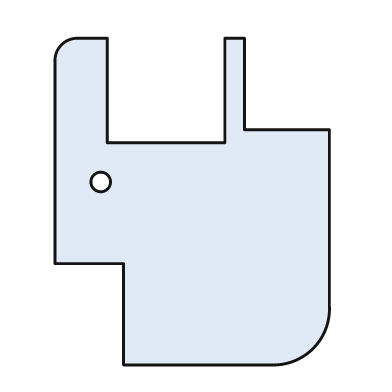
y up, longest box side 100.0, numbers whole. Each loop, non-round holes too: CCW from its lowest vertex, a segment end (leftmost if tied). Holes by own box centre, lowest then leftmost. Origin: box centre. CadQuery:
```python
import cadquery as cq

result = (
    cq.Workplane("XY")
    .moveTo(-21.0, -50.0)
    .lineTo(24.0, -50.0)
    .threePointArc((37.0, -45.0), (42.0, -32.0))
    .lineTo(42.0, 22.0)
    .lineTo(16.0, 22.0)
    .lineTo(16.0, 50.0)
    .lineTo(10.0, 50.0)
    .lineTo(10.0, 18.0)
    .lineTo(-26.0, 18.0)
    .lineTo(-26.0, 50.0)
    .lineTo(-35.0, 50.0)
    .threePointArc((-40.0, 48.0), (-42.0, 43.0))
    .lineTo(-42.0, -19.0)
    .lineTo(-21.0, -19.0)
    .close()
    .moveTo(-28.0, 6.0)
    .circle(3.0)
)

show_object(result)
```